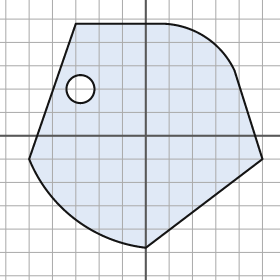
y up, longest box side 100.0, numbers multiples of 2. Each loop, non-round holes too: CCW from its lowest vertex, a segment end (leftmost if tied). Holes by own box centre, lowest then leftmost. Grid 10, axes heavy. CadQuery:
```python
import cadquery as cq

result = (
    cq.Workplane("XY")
    .moveTo(0.0, -48.0)
    .lineTo(50.0, -10.0)
    .lineTo(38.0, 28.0)
    .threePointArc((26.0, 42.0), (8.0, 48.0))
    .lineTo(-30.0, 48.0)
    .lineTo(-50.0, -10.0)
    .threePointArc((-30.0, -36.0), (0.0, -48.0))
    .close()
    .moveTo(-28.0, 20.0)
    .circle(6.0)
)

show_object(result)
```